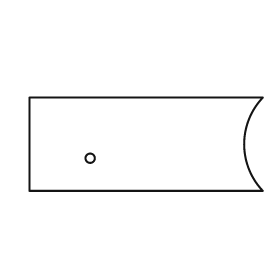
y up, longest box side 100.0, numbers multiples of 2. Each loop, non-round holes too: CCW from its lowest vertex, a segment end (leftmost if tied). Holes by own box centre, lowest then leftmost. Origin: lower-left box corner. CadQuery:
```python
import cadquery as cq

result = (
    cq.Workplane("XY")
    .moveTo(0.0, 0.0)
    .lineTo(100.0, 0.0)
    .threePointArc((92.0, 20.0), (100.0, 40.0))
    .lineTo(0.0, 40.0)
    .close()
    .moveTo(26.0, 14.0)
    .circle(2.0)
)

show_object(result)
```